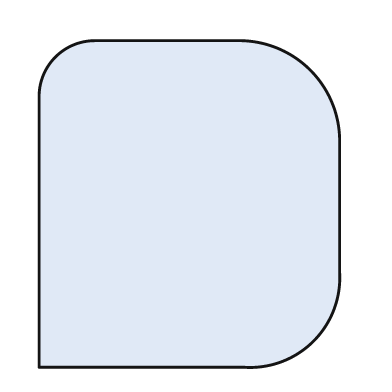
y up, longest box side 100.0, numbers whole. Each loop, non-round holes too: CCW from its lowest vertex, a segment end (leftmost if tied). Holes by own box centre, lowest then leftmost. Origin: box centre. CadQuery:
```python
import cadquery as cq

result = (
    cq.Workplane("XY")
    .moveTo(-46.0, -50.0)
    .lineTo(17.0, -50.0)
    .threePointArc((38.0, -42.0), (46.0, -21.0))
    .lineTo(46.0, 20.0)
    .threePointArc((37.0, 41.0), (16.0, 50.0))
    .lineTo(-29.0, 50.0)
    .threePointArc((-41.0, 45.0), (-46.0, 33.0))
    .close()
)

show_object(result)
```